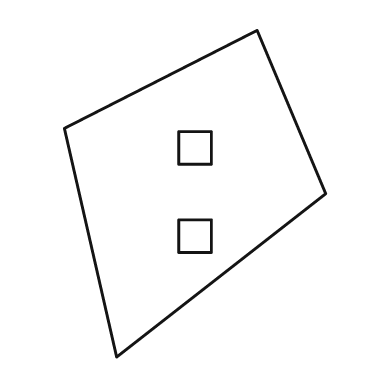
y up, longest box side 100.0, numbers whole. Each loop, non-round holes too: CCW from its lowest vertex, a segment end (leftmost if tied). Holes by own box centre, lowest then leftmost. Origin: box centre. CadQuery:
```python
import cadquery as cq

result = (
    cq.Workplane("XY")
    .moveTo(-24.0, -50.0)
    .lineTo(40.0, 0.0)
    .lineTo(19.0, 50.0)
    .lineTo(-40.0, 20.0)
    .close()
    .moveTo(-5.0, -18.0)
    .lineTo(5.0, -18.0)
    .lineTo(5.0, -8.0)
    .lineTo(-5.0, -8.0)
    .close()
    .moveTo(-5.0, 9.0)
    .lineTo(5.0, 9.0)
    .lineTo(5.0, 19.0)
    .lineTo(-5.0, 19.0)
    .close()
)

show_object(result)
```